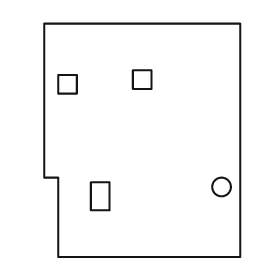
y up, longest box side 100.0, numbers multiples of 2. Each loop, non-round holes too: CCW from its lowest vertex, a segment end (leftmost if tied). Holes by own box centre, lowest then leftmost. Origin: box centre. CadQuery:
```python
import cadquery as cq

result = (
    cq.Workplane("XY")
    .moveTo(-36.0, -50.0)
    .lineTo(42.0, -50.0)
    .lineTo(42.0, 50.0)
    .lineTo(-42.0, 50.0)
    .lineTo(-42.0, -16.0)
    .lineTo(-36.0, -16.0)
    .close()
    .moveTo(-22.0, -30.0)
    .lineTo(-14.0, -30.0)
    .lineTo(-14.0, -18.0)
    .lineTo(-22.0, -18.0)
    .close()
    .moveTo(34.0, -20.0)
    .circle(4.0)
    .moveTo(-36.0, 20.0)
    .lineTo(-28.0, 20.0)
    .lineTo(-28.0, 28.0)
    .lineTo(-36.0, 28.0)
    .close()
    .moveTo(-4.0, 22.0)
    .lineTo(4.0, 22.0)
    .lineTo(4.0, 30.0)
    .lineTo(-4.0, 30.0)
    .close()
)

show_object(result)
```